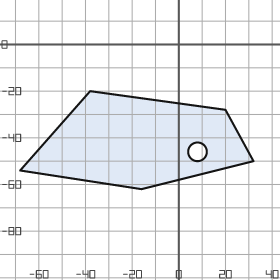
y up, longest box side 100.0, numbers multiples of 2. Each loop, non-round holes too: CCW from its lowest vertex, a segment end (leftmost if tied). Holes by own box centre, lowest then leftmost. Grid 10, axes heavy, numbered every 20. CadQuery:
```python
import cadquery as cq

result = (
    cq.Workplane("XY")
    .moveTo(-16.0, -62.0)
    .lineTo(32.0, -50.0)
    .lineTo(20.0, -28.0)
    .lineTo(-38.0, -20.0)
    .lineTo(-68.0, -54.0)
    .close()
    .moveTo(8.0, -46.0)
    .circle(4.0)
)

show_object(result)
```